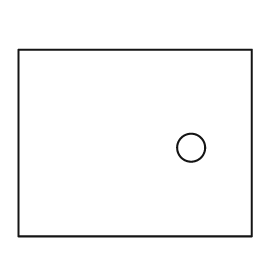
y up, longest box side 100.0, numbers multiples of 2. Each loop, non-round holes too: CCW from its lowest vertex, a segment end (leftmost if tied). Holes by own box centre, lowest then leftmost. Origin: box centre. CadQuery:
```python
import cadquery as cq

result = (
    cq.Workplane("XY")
    .moveTo(-50.0, -40.0)
    .lineTo(50.0, -40.0)
    .lineTo(50.0, 40.0)
    .lineTo(-50.0, 40.0)
    .close()
    .moveTo(24.0, -2.0)
    .circle(6.0)
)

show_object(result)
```